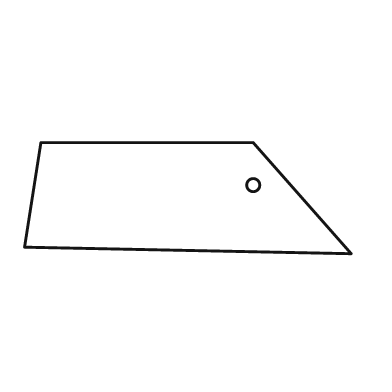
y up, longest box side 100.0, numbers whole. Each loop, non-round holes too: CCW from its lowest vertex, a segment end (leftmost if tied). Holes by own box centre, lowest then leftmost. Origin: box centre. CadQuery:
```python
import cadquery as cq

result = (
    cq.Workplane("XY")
    .moveTo(50.0, -17.0)
    .lineTo(20.0, 17.0)
    .lineTo(-45.0, 17.0)
    .lineTo(-50.0, -15.0)
    .close()
    .moveTo(20.0, 4.0)
    .circle(2.0)
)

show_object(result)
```